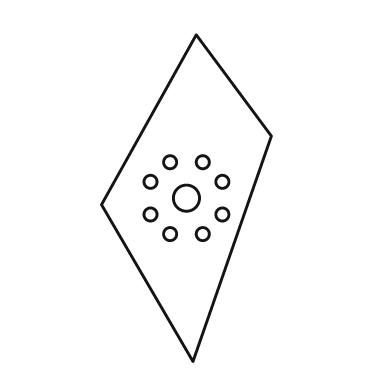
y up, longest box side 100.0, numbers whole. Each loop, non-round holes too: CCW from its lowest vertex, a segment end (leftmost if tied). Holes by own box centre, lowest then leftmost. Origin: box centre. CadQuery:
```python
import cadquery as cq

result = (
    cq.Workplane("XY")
    .moveTo(2.0, -50.0)
    .lineTo(26.0, 19.0)
    .lineTo(3.0, 50.0)
    .lineTo(-26.0, -2.0)
    .close()
    .moveTo(-5.0, -11.0)
    .circle(2.0)
    .moveTo(5.0, -11.0)
    .circle(2.0)
    .moveTo(-11.0, -5.0)
    .circle(2.0)
    .moveTo(11.0, -5.0)
    .circle(2.0)
    .moveTo(0.0, 0.0)
    .circle(4.0)
    .moveTo(-11.0, 5.0)
    .circle(2.0)
    .moveTo(11.0, 5.0)
    .circle(2.0)
    .moveTo(-5.0, 11.0)
    .circle(2.0)
    .moveTo(5.0, 11.0)
    .circle(2.0)
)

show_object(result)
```